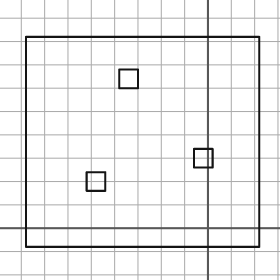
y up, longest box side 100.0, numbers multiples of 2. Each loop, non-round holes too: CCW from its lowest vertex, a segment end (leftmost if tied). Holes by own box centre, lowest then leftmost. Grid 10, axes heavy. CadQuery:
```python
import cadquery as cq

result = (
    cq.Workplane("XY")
    .moveTo(-78.0, -8.0)
    .lineTo(22.0, -8.0)
    .lineTo(22.0, 82.0)
    .lineTo(-78.0, 82.0)
    .close()
    .moveTo(-52.0, 16.0)
    .lineTo(-44.0, 16.0)
    .lineTo(-44.0, 24.0)
    .lineTo(-52.0, 24.0)
    .close()
    .moveTo(-6.0, 26.0)
    .lineTo(2.0, 26.0)
    .lineTo(2.0, 34.0)
    .lineTo(-6.0, 34.0)
    .close()
    .moveTo(-38.0, 60.0)
    .lineTo(-30.0, 60.0)
    .lineTo(-30.0, 68.0)
    .lineTo(-38.0, 68.0)
    .close()
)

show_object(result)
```